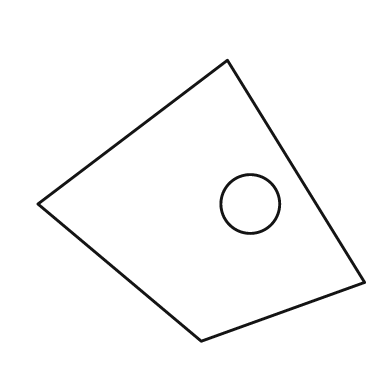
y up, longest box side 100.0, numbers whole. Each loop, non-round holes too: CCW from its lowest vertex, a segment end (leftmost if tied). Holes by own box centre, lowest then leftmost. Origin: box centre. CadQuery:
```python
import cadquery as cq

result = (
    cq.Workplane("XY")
    .moveTo(0.0, -43.0)
    .lineTo(50.0, -25.0)
    .lineTo(8.0, 43.0)
    .lineTo(-50.0, -1.0)
    .close()
    .moveTo(15.0, -1.0)
    .circle(9.0)
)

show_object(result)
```